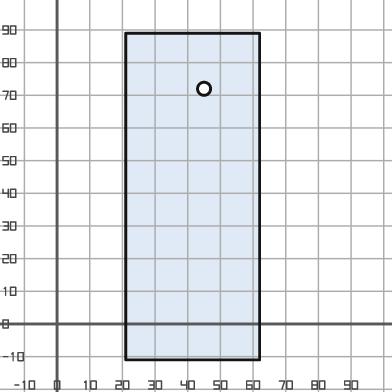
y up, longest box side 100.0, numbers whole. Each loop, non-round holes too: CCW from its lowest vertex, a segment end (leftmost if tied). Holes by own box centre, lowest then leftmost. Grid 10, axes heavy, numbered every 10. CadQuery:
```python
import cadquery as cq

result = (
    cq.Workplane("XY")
    .moveTo(21.0, -11.0)
    .lineTo(62.0, -11.0)
    .lineTo(62.0, 89.0)
    .lineTo(21.0, 89.0)
    .close()
    .moveTo(45.0, 72.0)
    .circle(2.0)
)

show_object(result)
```